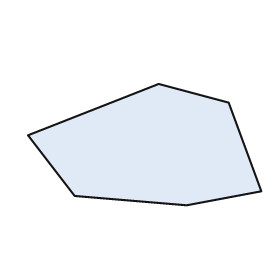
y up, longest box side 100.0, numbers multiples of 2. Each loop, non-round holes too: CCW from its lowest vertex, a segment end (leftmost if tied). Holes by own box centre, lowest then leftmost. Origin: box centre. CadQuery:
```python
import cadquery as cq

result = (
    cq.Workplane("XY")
    .moveTo(18.0, -26.0)
    .lineTo(50.0, -20.0)
    .lineTo(36.0, 18.0)
    .lineTo(6.0, 26.0)
    .lineTo(-50.0, 4.0)
    .lineTo(-30.0, -22.0)
    .close()
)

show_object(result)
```